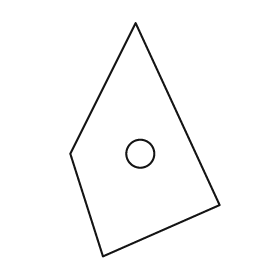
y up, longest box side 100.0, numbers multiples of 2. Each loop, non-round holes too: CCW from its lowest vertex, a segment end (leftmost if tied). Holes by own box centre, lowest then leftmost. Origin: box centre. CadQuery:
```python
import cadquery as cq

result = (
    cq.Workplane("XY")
    .moveTo(-18.0, -50.0)
    .lineTo(32.0, -28.0)
    .lineTo(-4.0, 50.0)
    .lineTo(-32.0, -6.0)
    .close()
    .moveTo(-2.0, -6.0)
    .circle(6.0)
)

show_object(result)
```